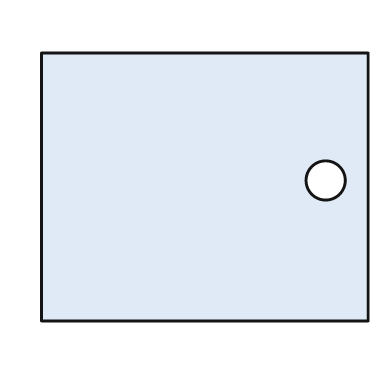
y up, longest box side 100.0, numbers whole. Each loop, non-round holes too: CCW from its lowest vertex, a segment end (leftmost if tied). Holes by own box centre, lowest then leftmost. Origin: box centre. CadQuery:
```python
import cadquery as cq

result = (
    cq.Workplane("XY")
    .moveTo(-50.0, -41.0)
    .lineTo(50.0, -41.0)
    .lineTo(50.0, 41.0)
    .lineTo(-50.0, 41.0)
    .close()
    .moveTo(37.0, 2.0)
    .circle(6.0)
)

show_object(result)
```